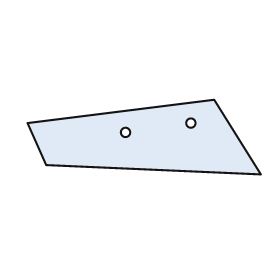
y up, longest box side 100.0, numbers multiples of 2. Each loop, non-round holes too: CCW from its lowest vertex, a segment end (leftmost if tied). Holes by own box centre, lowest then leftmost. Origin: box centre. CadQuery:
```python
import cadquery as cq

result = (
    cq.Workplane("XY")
    .moveTo(50.0, -16.0)
    .lineTo(30.0, 16.0)
    .lineTo(-50.0, 6.0)
    .lineTo(-42.0, -12.0)
    .close()
    .moveTo(-8.0, 2.0)
    .circle(2.0)
    .moveTo(20.0, 6.0)
    .circle(2.0)
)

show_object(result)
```